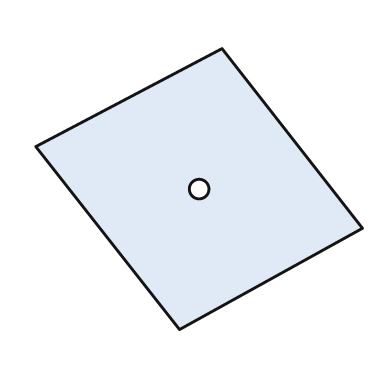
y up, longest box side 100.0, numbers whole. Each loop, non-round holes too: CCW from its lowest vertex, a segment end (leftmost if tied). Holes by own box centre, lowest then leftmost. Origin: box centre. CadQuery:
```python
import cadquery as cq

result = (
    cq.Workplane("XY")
    .moveTo(-6.0, -43.0)
    .lineTo(50.0, -12.0)
    .lineTo(7.0, 43.0)
    .lineTo(-50.0, 13.0)
    .close()
    .moveTo(0.0, 0.0)
    .circle(3.0)
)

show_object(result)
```